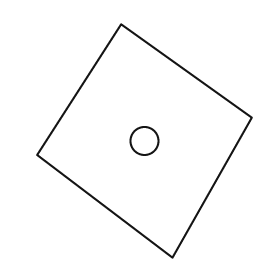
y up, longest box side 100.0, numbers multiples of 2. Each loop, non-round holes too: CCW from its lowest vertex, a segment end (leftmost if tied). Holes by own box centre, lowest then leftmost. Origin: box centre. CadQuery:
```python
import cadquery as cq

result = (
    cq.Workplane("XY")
    .moveTo(12.0, -50.0)
    .lineTo(46.0, 10.0)
    .lineTo(-10.0, 50.0)
    .lineTo(-46.0, -6.0)
    .close()
    .moveTo(0.0, 0.0)
    .circle(6.0)
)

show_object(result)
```